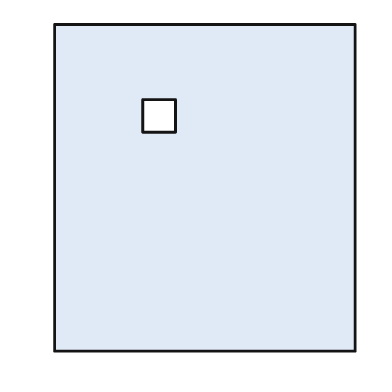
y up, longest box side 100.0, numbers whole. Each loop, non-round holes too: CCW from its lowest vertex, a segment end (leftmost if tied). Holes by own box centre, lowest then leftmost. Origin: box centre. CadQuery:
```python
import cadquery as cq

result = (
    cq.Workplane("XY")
    .moveTo(-46.0, -50.0)
    .lineTo(46.0, -50.0)
    .lineTo(46.0, 50.0)
    .lineTo(-46.0, 50.0)
    .close()
    .moveTo(-19.0, 17.0)
    .lineTo(-9.0, 17.0)
    .lineTo(-9.0, 27.0)
    .lineTo(-19.0, 27.0)
    .close()
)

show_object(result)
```